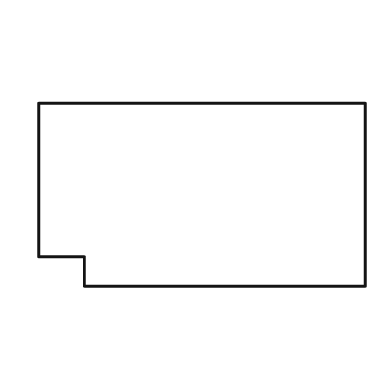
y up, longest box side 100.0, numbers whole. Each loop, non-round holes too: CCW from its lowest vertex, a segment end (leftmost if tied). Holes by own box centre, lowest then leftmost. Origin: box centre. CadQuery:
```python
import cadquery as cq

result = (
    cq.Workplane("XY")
    .moveTo(-36.0, -28.0)
    .lineTo(50.0, -28.0)
    .lineTo(50.0, 28.0)
    .lineTo(-50.0, 28.0)
    .lineTo(-50.0, -19.0)
    .lineTo(-36.0, -19.0)
    .close()
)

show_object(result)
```